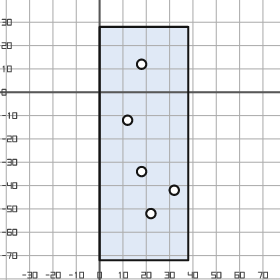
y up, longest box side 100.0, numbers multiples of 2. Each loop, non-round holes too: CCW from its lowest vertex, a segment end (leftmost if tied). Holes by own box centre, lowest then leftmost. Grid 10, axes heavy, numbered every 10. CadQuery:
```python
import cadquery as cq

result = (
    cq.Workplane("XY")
    .moveTo(0.0, -72.0)
    .lineTo(38.0, -72.0)
    .lineTo(38.0, 28.0)
    .lineTo(0.0, 28.0)
    .close()
    .moveTo(22.0, -52.0)
    .circle(2.0)
    .moveTo(32.0, -42.0)
    .circle(2.0)
    .moveTo(18.0, -34.0)
    .circle(2.0)
    .moveTo(12.0, -12.0)
    .circle(2.0)
    .moveTo(18.0, 12.0)
    .circle(2.0)
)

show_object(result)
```